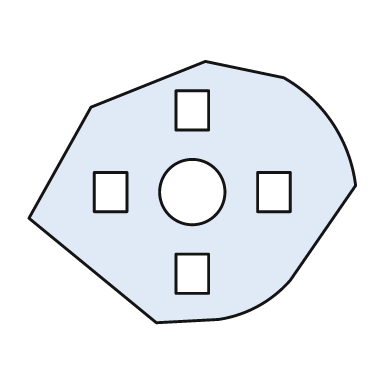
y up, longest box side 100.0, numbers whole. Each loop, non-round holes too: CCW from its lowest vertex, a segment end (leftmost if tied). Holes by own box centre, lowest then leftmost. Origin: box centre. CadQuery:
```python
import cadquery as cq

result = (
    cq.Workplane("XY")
    .moveTo(-11.0, -40.0)
    .lineTo(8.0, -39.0)
    .threePointArc((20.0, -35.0), (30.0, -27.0))
    .lineTo(50.0, 2.0)
    .threePointArc((43.0, 21.0), (28.0, 35.0))
    .lineTo(4.0, 40.0)
    .lineTo(-31.0, 26.0)
    .lineTo(-50.0, -8.0)
    .close()
    .moveTo(-5.0, -31.0)
    .lineTo(5.0, -31.0)
    .lineTo(5.0, -19.0)
    .lineTo(-5.0, -19.0)
    .close()
    .moveTo(-30.0, -6.0)
    .lineTo(-20.0, -6.0)
    .lineTo(-20.0, 6.0)
    .lineTo(-30.0, 6.0)
    .close()
    .moveTo(0.0, 0.0)
    .circle(10.0)
    .moveTo(20.0, -6.0)
    .lineTo(30.0, -6.0)
    .lineTo(30.0, 6.0)
    .lineTo(20.0, 6.0)
    .close()
    .moveTo(-5.0, 19.0)
    .lineTo(5.0, 19.0)
    .lineTo(5.0, 31.0)
    .lineTo(-5.0, 31.0)
    .close()
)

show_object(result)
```